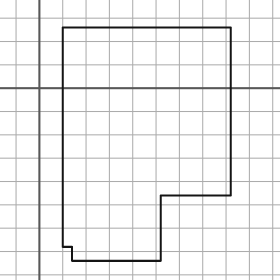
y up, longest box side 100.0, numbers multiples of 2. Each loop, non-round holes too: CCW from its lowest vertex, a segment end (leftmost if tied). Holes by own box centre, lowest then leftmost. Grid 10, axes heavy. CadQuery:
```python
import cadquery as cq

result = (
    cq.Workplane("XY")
    .moveTo(14.0, -74.0)
    .lineTo(52.0, -74.0)
    .lineTo(52.0, -46.0)
    .lineTo(82.0, -46.0)
    .lineTo(82.0, 26.0)
    .lineTo(10.0, 26.0)
    .lineTo(10.0, -68.0)
    .lineTo(14.0, -68.0)
    .close()
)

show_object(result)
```